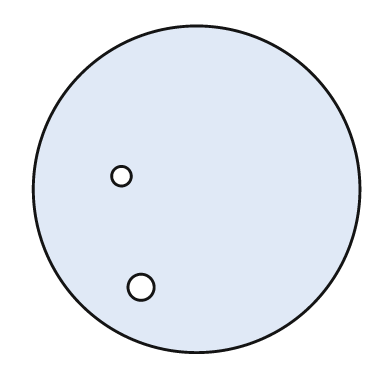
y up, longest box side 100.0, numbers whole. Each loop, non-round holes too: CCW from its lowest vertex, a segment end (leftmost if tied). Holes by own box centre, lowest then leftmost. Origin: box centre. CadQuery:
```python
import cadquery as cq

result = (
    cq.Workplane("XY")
    .moveTo(0.0, 0.0)
    .circle(50.0)
    .moveTo(-17.0, -30.0)
    .circle(4.0)
    .moveTo(-23.0, 4.0)
    .circle(3.0)
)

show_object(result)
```